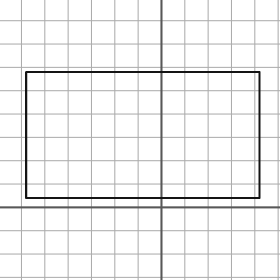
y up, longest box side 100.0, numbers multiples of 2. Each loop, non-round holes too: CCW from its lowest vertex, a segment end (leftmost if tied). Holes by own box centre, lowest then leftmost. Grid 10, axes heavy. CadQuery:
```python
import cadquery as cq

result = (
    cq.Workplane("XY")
    .moveTo(-58.0, 4.0)
    .lineTo(42.0, 4.0)
    .lineTo(42.0, 58.0)
    .lineTo(-58.0, 58.0)
    .close()
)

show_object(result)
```